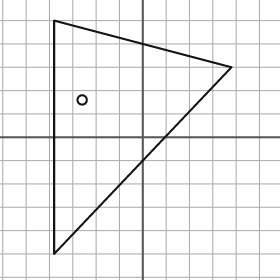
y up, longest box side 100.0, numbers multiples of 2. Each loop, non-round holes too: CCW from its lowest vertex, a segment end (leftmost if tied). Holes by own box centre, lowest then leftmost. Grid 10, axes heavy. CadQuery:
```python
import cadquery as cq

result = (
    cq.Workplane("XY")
    .moveTo(-38.0, -50.0)
    .lineTo(38.0, 30.0)
    .lineTo(-38.0, 50.0)
    .close()
    .moveTo(-26.0, 16.0)
    .circle(2.0)
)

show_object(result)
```